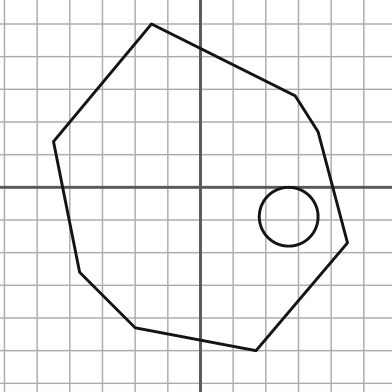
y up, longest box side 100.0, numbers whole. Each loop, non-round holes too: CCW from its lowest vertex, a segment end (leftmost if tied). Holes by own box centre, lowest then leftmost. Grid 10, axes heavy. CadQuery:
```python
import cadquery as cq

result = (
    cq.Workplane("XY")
    .moveTo(17.0, -50.0)
    .lineTo(45.0, -17.0)
    .lineTo(36.0, 17.0)
    .lineTo(29.0, 28.0)
    .lineTo(-15.0, 50.0)
    .lineTo(-45.0, 14.0)
    .lineTo(-37.0, -26.0)
    .lineTo(-20.0, -43.0)
    .close()
    .moveTo(27.0, -9.0)
    .circle(9.0)
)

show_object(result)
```